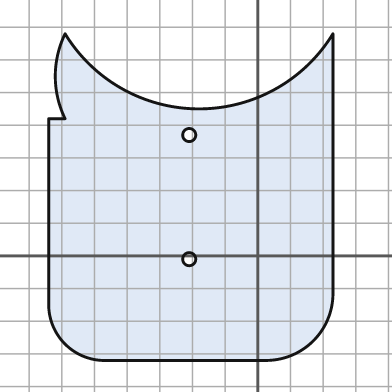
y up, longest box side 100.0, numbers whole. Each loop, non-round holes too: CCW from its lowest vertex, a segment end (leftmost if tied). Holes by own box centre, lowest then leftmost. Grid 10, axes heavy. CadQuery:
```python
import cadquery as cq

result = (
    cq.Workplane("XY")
    .moveTo(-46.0, -32.0)
    .lineTo(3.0, -32.0)
    .threePointArc((17.0, -26.0), (23.0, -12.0))
    .lineTo(23.0, 68.0)
    .threePointArc((-18.0, 45.0), (-59.0, 68.0))
    .threePointArc((-62.0, 55.0), (-59.0, 42.0))
    .lineTo(-64.0, 42.0)
    .lineTo(-64.0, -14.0)
    .threePointArc((-59.0, -27.0), (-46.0, -32.0))
    .close()
    .moveTo(-21.0, -1.0)
    .circle(2.0)
    .moveTo(-21.0, 37.0)
    .circle(2.0)
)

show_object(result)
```